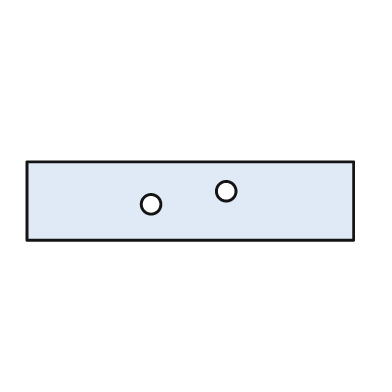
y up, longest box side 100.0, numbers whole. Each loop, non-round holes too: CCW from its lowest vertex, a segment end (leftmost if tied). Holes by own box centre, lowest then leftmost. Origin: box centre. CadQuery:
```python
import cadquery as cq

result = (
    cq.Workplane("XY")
    .moveTo(-50.0, -12.0)
    .lineTo(50.0, -12.0)
    .lineTo(50.0, 12.0)
    .lineTo(-50.0, 12.0)
    .close()
    .moveTo(-12.0, -1.0)
    .circle(3.0)
    .moveTo(11.0, 3.0)
    .circle(3.0)
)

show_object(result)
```